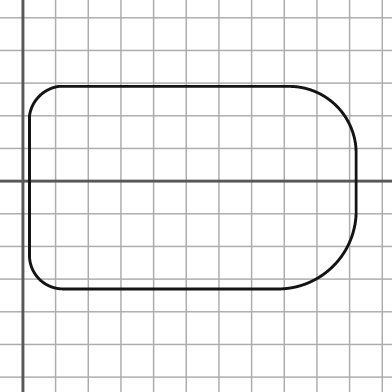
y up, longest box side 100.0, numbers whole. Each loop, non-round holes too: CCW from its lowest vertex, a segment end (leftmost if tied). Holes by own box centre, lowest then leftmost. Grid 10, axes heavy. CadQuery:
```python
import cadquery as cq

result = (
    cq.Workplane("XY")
    .moveTo(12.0, -33.0)
    .lineTo(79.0, -33.0)
    .threePointArc((95.0, -26.0), (102.0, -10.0))
    .lineTo(102.0, 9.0)
    .threePointArc((96.0, 23.0), (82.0, 29.0))
    .lineTo(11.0, 29.0)
    .threePointArc((5.0, 26.0), (2.0, 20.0))
    .lineTo(2.0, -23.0)
    .threePointArc((5.0, -30.0), (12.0, -33.0))
    .close()
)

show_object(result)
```